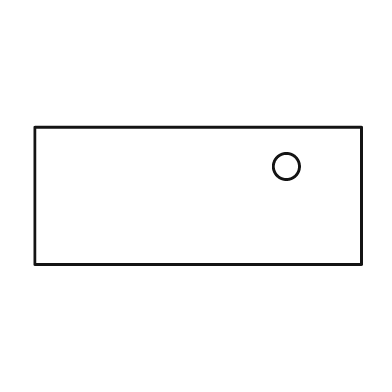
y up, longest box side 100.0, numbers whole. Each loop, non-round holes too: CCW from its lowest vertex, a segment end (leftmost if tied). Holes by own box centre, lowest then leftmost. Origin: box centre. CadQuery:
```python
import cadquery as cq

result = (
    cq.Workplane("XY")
    .moveTo(-50.0, -21.0)
    .lineTo(50.0, -21.0)
    .lineTo(50.0, 21.0)
    .lineTo(-50.0, 21.0)
    .close()
    .moveTo(27.0, 9.0)
    .circle(4.0)
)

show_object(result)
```